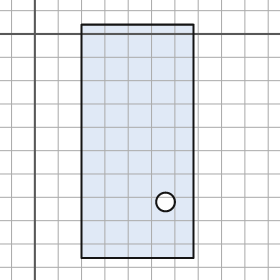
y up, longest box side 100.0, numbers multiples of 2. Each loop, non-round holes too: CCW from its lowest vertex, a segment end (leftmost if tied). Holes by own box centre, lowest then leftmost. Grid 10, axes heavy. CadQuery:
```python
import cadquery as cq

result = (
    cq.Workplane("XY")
    .moveTo(20.0, -96.0)
    .lineTo(68.0, -96.0)
    .lineTo(68.0, 4.0)
    .lineTo(20.0, 4.0)
    .close()
    .moveTo(56.0, -72.0)
    .circle(4.0)
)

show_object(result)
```